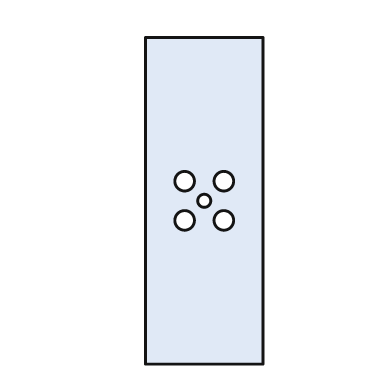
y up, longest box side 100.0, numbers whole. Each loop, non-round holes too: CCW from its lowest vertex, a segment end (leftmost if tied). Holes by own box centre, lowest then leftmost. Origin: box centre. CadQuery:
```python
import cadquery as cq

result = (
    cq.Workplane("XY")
    .moveTo(-18.0, -50.0)
    .lineTo(18.0, -50.0)
    .lineTo(18.0, 50.0)
    .lineTo(-18.0, 50.0)
    .close()
    .moveTo(-6.0, -6.0)
    .circle(3.0)
    .moveTo(6.0, -6.0)
    .circle(3.0)
    .moveTo(0.0, 0.0)
    .circle(2.0)
    .moveTo(-6.0, 6.0)
    .circle(3.0)
    .moveTo(6.0, 6.0)
    .circle(3.0)
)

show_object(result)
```